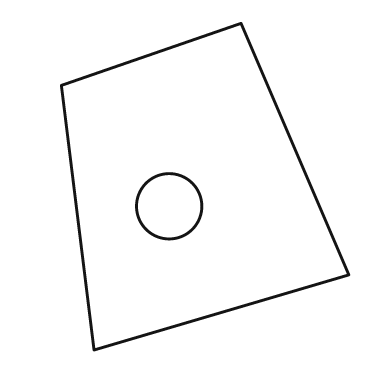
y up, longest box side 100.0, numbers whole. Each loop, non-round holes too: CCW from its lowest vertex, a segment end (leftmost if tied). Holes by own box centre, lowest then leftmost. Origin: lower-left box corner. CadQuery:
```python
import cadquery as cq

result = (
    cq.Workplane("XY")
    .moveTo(10.0, 0.0)
    .lineTo(88.0, 23.0)
    .lineTo(55.0, 100.0)
    .lineTo(0.0, 81.0)
    .close()
    .moveTo(33.0, 44.0)
    .circle(10.0)
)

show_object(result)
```